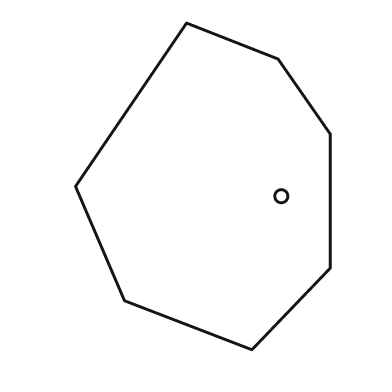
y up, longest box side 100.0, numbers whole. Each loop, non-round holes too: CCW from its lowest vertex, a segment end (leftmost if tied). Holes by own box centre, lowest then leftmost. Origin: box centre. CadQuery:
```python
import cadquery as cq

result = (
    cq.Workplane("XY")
    .moveTo(15.0, -50.0)
    .lineTo(39.0, -25.0)
    .lineTo(39.0, 16.0)
    .lineTo(23.0, 39.0)
    .lineTo(-5.0, 50.0)
    .lineTo(-39.0, 0.0)
    .lineTo(-24.0, -35.0)
    .close()
    .moveTo(24.0, -3.0)
    .circle(2.0)
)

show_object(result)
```